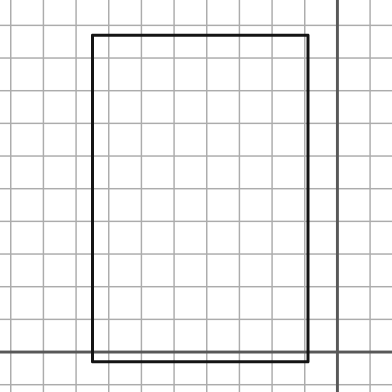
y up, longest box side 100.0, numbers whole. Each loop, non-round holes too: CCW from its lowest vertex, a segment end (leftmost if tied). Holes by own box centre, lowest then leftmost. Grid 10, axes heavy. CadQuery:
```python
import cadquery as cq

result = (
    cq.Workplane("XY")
    .moveTo(-75.0, -3.0)
    .lineTo(-9.0, -3.0)
    .lineTo(-9.0, 97.0)
    .lineTo(-75.0, 97.0)
    .close()
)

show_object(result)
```